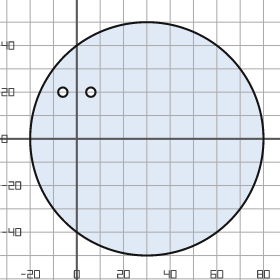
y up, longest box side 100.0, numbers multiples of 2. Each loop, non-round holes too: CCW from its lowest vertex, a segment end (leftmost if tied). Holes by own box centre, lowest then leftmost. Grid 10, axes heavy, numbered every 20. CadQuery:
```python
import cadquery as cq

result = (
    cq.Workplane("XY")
    .moveTo(30.0, 0.0)
    .circle(50.0)
    .moveTo(-6.0, 20.0)
    .circle(2.0)
    .moveTo(6.0, 20.0)
    .circle(2.0)
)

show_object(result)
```